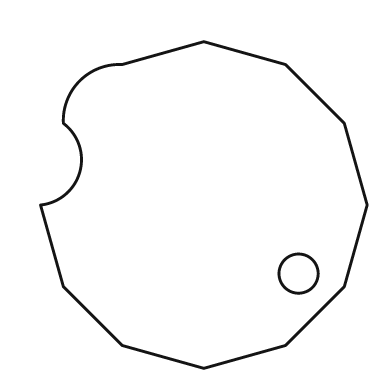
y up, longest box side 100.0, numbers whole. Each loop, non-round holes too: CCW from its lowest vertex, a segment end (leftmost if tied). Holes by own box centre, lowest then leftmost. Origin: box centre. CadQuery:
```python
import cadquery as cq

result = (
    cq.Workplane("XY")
    .moveTo(0.0, -50.0)
    .lineTo(25.0, -43.0)
    .lineTo(43.0, -25.0)
    .lineTo(50.0, 0.0)
    .lineTo(43.0, 25.0)
    .lineTo(25.0, 43.0)
    .lineTo(0.0, 50.0)
    .lineTo(-25.0, 43.0)
    .threePointArc((-38.0, 38.0), (-43.0, 25.0))
    .threePointArc((-38.0, 10.0), (-50.0, 0.0))
    .lineTo(-43.0, -25.0)
    .lineTo(-25.0, -43.0)
    .close()
    .moveTo(29.0, -21.0)
    .circle(6.0)
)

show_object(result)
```